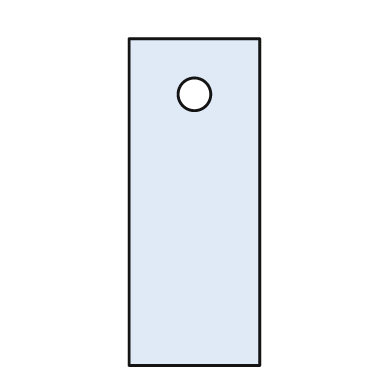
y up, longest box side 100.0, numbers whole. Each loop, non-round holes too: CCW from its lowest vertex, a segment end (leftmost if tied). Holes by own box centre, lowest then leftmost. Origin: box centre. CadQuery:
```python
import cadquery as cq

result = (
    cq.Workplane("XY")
    .moveTo(-20.0, -50.0)
    .lineTo(20.0, -50.0)
    .lineTo(20.0, 50.0)
    .lineTo(-20.0, 50.0)
    .close()
    .moveTo(0.0, 33.0)
    .circle(5.0)
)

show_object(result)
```